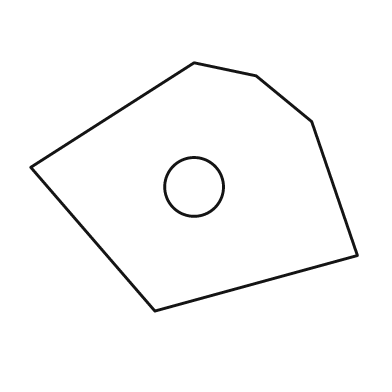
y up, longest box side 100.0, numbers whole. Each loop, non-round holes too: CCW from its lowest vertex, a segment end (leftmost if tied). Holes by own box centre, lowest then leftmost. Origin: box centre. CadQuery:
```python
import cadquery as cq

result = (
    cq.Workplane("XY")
    .moveTo(-12.0, -38.0)
    .lineTo(50.0, -21.0)
    .lineTo(36.0, 20.0)
    .lineTo(19.0, 34.0)
    .lineTo(0.0, 38.0)
    .lineTo(-50.0, 6.0)
    .close()
    .moveTo(0.0, 0.0)
    .circle(9.0)
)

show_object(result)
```